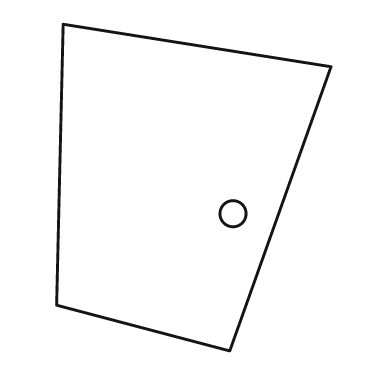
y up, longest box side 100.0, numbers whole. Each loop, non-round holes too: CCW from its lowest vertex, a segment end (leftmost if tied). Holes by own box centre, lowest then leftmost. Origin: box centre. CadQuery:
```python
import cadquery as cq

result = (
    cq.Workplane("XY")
    .moveTo(11.0, -50.0)
    .lineTo(42.0, 37.0)
    .lineTo(-40.0, 50.0)
    .lineTo(-42.0, -36.0)
    .close()
    .moveTo(12.0, -8.0)
    .circle(4.0)
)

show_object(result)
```